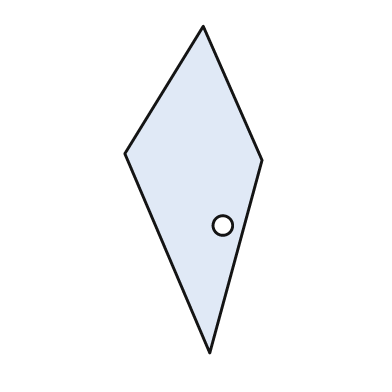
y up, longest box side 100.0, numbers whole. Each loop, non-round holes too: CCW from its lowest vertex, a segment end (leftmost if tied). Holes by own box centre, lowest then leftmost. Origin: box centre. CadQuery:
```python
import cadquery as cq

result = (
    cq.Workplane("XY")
    .moveTo(5.0, -50.0)
    .lineTo(21.0, 9.0)
    .lineTo(3.0, 50.0)
    .lineTo(-21.0, 11.0)
    .close()
    .moveTo(9.0, -11.0)
    .circle(3.0)
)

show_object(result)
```